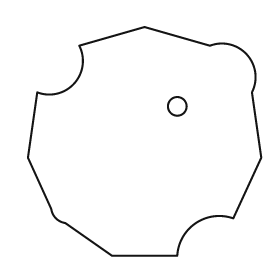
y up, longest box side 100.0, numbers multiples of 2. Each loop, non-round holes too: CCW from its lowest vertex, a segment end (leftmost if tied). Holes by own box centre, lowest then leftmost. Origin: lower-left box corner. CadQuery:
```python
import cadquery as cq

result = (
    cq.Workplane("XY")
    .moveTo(36.0, 0.0)
    .lineTo(64.0, 0.0)
    .threePointArc((72.0, 14.0), (88.0, 16.0))
    .lineTo(100.0, 42.0)
    .lineTo(96.0, 70.0)
    .threePointArc((94.0, 86.0), (78.0, 90.0))
    .lineTo(50.0, 98.0)
    .lineTo(22.0, 90.0)
    .threePointArc((20.0, 74.0), (4.0, 70.0))
    .lineTo(0.0, 42.0)
    .lineTo(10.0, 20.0)
    .threePointArc((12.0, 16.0), (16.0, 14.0))
    .close()
    .moveTo(64.0, 64.0)
    .circle(4.0)
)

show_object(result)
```